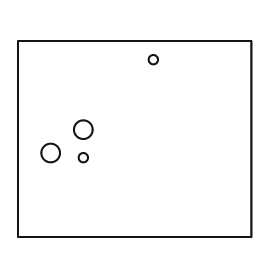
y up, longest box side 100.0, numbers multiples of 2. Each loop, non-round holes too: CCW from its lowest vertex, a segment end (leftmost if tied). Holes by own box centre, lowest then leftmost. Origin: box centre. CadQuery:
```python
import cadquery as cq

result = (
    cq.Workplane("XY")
    .moveTo(-50.0, -42.0)
    .lineTo(50.0, -42.0)
    .lineTo(50.0, 42.0)
    .lineTo(-50.0, 42.0)
    .close()
    .moveTo(-22.0, -8.0)
    .circle(2.0)
    .moveTo(-36.0, -6.0)
    .circle(4.0)
    .moveTo(-22.0, 4.0)
    .circle(4.0)
    .moveTo(8.0, 34.0)
    .circle(2.0)
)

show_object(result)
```